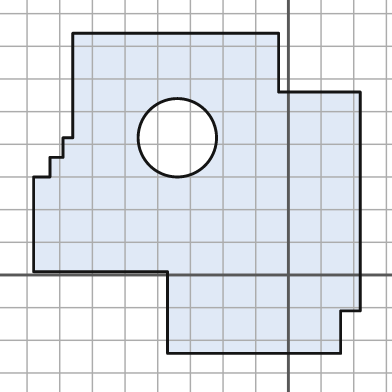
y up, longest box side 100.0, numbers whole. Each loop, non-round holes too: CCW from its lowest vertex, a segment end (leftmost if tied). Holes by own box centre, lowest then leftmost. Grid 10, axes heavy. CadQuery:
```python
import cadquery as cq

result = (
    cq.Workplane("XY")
    .moveTo(-37.0, -24.0)
    .lineTo(16.0, -24.0)
    .lineTo(16.0, -11.0)
    .lineTo(22.0, -11.0)
    .lineTo(22.0, 56.0)
    .lineTo(-3.0, 56.0)
    .lineTo(-3.0, 74.0)
    .lineTo(-66.0, 74.0)
    .lineTo(-66.0, 42.0)
    .lineTo(-69.0, 42.0)
    .lineTo(-69.0, 36.0)
    .lineTo(-73.0, 36.0)
    .lineTo(-73.0, 30.0)
    .lineTo(-78.0, 30.0)
    .lineTo(-78.0, 1.0)
    .lineTo(-37.0, 1.0)
    .close()
    .moveTo(-34.0, 42.0)
    .circle(12.0)
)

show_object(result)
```